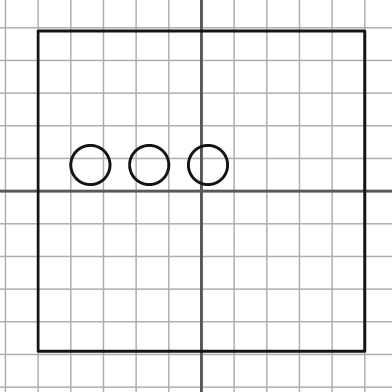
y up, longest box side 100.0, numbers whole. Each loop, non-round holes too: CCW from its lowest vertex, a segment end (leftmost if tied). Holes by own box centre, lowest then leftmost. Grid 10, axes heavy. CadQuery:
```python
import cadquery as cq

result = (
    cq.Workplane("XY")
    .moveTo(-50.0, -49.0)
    .lineTo(50.0, -49.0)
    .lineTo(50.0, 49.0)
    .lineTo(-50.0, 49.0)
    .close()
    .moveTo(-34.0, 8.0)
    .circle(6.0)
    .moveTo(-16.0, 8.0)
    .circle(6.0)
    .moveTo(2.0, 8.0)
    .circle(6.0)
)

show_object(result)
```